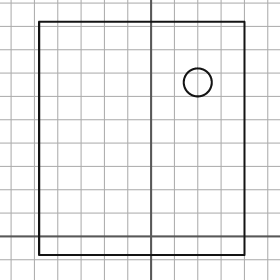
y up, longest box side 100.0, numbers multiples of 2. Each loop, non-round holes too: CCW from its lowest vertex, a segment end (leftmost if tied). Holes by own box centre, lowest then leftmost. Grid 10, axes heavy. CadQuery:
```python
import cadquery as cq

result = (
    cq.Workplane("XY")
    .moveTo(-48.0, -8.0)
    .lineTo(40.0, -8.0)
    .lineTo(40.0, 92.0)
    .lineTo(-48.0, 92.0)
    .close()
    .moveTo(20.0, 66.0)
    .circle(6.0)
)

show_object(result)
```